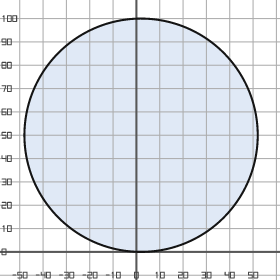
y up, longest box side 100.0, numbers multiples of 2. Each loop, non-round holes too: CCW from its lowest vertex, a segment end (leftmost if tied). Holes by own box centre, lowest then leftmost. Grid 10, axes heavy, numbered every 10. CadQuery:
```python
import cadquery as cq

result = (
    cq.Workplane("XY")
    .moveTo(2.0, 50.0)
    .circle(50.0)
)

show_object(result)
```